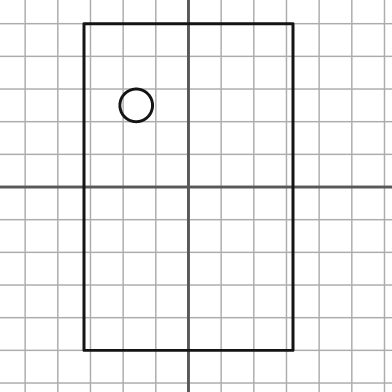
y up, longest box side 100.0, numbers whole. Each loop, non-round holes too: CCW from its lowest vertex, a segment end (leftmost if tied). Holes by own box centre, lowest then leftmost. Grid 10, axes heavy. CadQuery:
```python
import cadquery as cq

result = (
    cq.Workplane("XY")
    .moveTo(-32.0, -50.0)
    .lineTo(32.0, -50.0)
    .lineTo(32.0, 50.0)
    .lineTo(-32.0, 50.0)
    .close()
    .moveTo(-16.0, 25.0)
    .circle(5.0)
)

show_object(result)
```